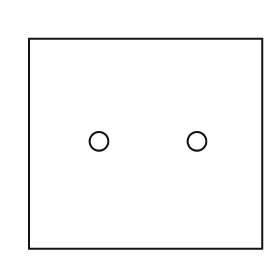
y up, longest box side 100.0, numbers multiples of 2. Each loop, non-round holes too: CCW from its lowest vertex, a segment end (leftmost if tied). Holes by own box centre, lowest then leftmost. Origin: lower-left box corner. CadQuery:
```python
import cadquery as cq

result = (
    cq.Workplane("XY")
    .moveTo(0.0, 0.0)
    .lineTo(100.0, 0.0)
    .lineTo(100.0, 90.0)
    .lineTo(0.0, 90.0)
    .close()
    .moveTo(30.0, 46.0)
    .circle(4.0)
    .moveTo(72.0, 46.0)
    .circle(4.0)
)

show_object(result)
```